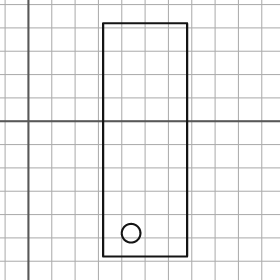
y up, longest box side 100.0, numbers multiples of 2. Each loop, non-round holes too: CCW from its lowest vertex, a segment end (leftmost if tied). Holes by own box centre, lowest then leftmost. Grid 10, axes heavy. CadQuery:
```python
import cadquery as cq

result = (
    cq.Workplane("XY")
    .moveTo(32.0, -58.0)
    .lineTo(68.0, -58.0)
    .lineTo(68.0, 42.0)
    .lineTo(32.0, 42.0)
    .close()
    .moveTo(44.0, -48.0)
    .circle(4.0)
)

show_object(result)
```